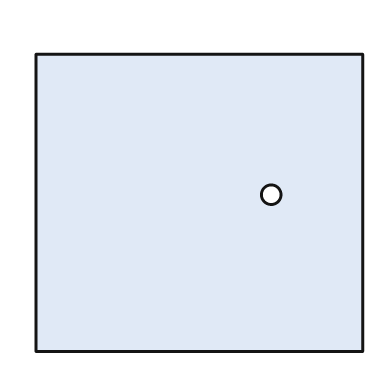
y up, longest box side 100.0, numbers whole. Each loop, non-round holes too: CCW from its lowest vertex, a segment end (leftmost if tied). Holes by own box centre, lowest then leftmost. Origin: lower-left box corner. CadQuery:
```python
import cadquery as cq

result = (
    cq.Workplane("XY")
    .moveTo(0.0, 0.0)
    .lineTo(100.0, 0.0)
    .lineTo(100.0, 91.0)
    .lineTo(0.0, 91.0)
    .close()
    .moveTo(72.0, 48.0)
    .circle(3.0)
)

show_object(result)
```